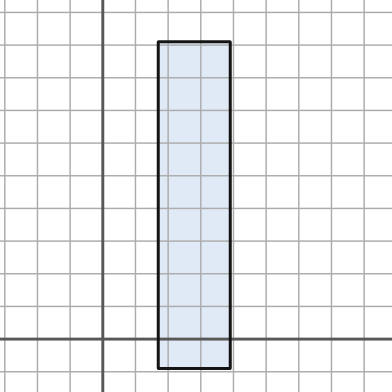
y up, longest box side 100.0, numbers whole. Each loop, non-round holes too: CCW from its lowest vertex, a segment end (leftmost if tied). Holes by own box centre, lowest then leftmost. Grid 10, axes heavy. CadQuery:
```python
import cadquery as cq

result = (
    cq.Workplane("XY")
    .moveTo(17.0, -9.0)
    .lineTo(39.0, -9.0)
    .lineTo(39.0, 91.0)
    .lineTo(17.0, 91.0)
    .close()
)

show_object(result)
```